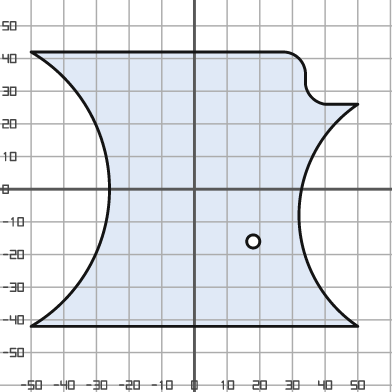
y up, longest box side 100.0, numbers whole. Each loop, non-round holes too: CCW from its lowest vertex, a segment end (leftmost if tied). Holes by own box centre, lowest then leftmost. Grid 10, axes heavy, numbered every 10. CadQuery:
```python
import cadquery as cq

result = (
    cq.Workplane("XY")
    .moveTo(-50.0, -42.0)
    .lineTo(50.0, -42.0)
    .threePointArc((32.0, -8.0), (50.0, 26.0))
    .lineTo(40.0, 26.0)
    .threePointArc((36.0, 28.0), (34.0, 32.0))
    .lineTo(34.0, 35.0)
    .threePointArc((32.0, 40.0), (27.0, 42.0))
    .lineTo(-50.0, 42.0)
    .threePointArc((-26.0, 0.0), (-50.0, -42.0))
    .close()
    .moveTo(18.0, -16.0)
    .circle(2.0)
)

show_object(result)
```